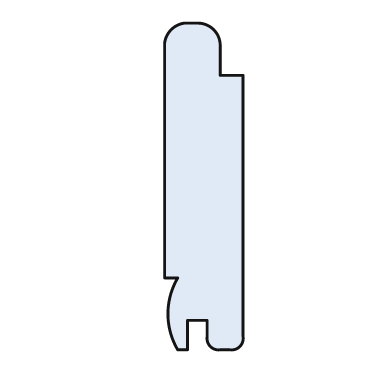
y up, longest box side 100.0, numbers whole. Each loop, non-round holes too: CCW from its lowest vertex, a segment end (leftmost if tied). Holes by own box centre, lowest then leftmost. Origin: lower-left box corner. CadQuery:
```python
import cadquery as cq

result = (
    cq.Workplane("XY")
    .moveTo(4.0, 0.0)
    .lineTo(7.0, 0.0)
    .lineTo(7.0, 9.0)
    .lineTo(13.0, 9.0)
    .lineTo(13.0, 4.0)
    .threePointArc((14.0, 1.0), (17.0, 0.0))
    .lineTo(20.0, 0.0)
    .threePointArc((23.0, 1.0), (24.0, 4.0))
    .lineTo(24.0, 84.0)
    .lineTo(17.0, 84.0)
    .lineTo(17.0, 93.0)
    .threePointArc((15.0, 98.0), (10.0, 100.0))
    .lineTo(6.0, 100.0)
    .threePointArc((2.0, 98.0), (0.0, 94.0))
    .lineTo(0.0, 22.0)
    .lineTo(4.0, 22.0)
    .threePointArc((1.0, 11.0), (4.0, 0.0))
    .close()
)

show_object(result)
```